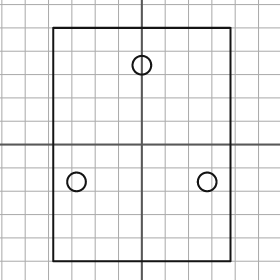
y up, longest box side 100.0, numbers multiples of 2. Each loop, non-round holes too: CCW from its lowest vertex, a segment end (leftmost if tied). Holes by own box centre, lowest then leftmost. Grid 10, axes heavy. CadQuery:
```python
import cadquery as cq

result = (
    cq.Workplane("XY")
    .moveTo(-38.0, -50.0)
    .lineTo(38.0, -50.0)
    .lineTo(38.0, 50.0)
    .lineTo(-38.0, 50.0)
    .close()
    .moveTo(-28.0, -16.0)
    .circle(4.0)
    .moveTo(28.0, -16.0)
    .circle(4.0)
    .moveTo(0.0, 34.0)
    .circle(4.0)
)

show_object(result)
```